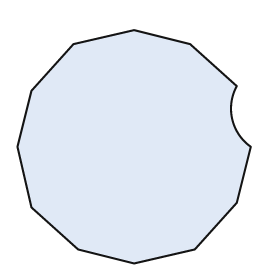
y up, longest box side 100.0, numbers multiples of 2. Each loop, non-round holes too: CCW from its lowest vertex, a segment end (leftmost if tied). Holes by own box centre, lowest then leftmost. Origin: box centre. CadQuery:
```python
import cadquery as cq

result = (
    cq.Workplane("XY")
    .moveTo(0.0, -50.0)
    .lineTo(26.0, -44.0)
    .lineTo(44.0, -24.0)
    .lineTo(50.0, 0.0)
    .threePointArc((42.0, 12.0), (44.0, 26.0))
    .lineTo(24.0, 44.0)
    .lineTo(0.0, 50.0)
    .lineTo(-26.0, 44.0)
    .lineTo(-44.0, 24.0)
    .lineTo(-50.0, 0.0)
    .lineTo(-44.0, -26.0)
    .lineTo(-24.0, -44.0)
    .close()
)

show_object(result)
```